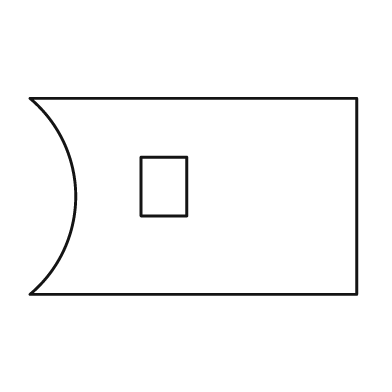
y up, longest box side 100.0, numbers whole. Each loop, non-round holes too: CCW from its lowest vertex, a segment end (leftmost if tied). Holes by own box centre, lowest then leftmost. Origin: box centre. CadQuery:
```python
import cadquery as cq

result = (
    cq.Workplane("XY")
    .moveTo(-50.0, -30.0)
    .lineTo(50.0, -30.0)
    .lineTo(50.0, 30.0)
    .lineTo(-50.0, 30.0)
    .threePointArc((-36.0, 0.0), (-50.0, -30.0))
    .close()
    .moveTo(-16.0, -6.0)
    .lineTo(-2.0, -6.0)
    .lineTo(-2.0, 12.0)
    .lineTo(-16.0, 12.0)
    .close()
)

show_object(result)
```